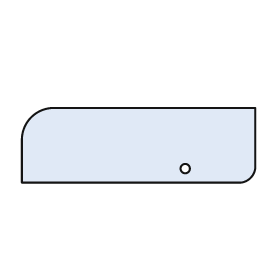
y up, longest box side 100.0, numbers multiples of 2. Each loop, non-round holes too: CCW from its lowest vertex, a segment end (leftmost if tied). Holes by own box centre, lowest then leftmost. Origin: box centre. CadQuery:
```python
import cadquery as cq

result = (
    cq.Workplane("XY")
    .moveTo(-50.0, -16.0)
    .lineTo(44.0, -16.0)
    .threePointArc((48.0, -14.0), (50.0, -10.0))
    .lineTo(50.0, 16.0)
    .lineTo(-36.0, 16.0)
    .threePointArc((-46.0, 12.0), (-50.0, 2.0))
    .close()
    .moveTo(20.0, -10.0)
    .circle(2.0)
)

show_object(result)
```